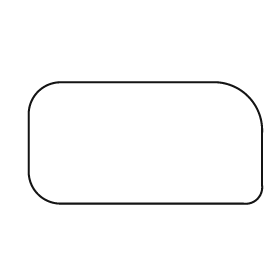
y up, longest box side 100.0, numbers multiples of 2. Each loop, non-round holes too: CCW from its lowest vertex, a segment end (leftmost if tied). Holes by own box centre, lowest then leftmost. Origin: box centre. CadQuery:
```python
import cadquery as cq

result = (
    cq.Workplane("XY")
    .moveTo(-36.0, -26.0)
    .lineTo(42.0, -26.0)
    .threePointArc((48.0, -24.0), (50.0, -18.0))
    .lineTo(50.0, 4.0)
    .threePointArc((44.0, 20.0), (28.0, 26.0))
    .lineTo(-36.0, 26.0)
    .threePointArc((-46.0, 22.0), (-50.0, 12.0))
    .lineTo(-50.0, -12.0)
    .threePointArc((-46.0, -22.0), (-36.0, -26.0))
    .close()
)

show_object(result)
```